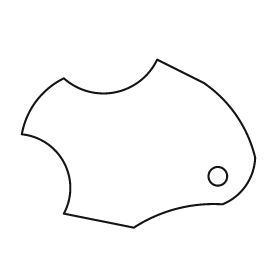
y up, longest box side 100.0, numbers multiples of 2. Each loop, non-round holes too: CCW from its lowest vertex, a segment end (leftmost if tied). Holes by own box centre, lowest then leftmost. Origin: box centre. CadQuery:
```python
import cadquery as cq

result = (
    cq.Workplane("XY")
    .moveTo(-2.0, -36.0)
    .threePointArc((16.0, -28.0), (36.0, -26.0))
    .threePointArc((46.0, -18.0), (50.0, -6.0))
    .threePointArc((42.0, 12.0), (28.0, 26.0))
    .lineTo(8.0, 36.0)
    .threePointArc((-10.0, 22.0), (-32.0, 28.0))
    .threePointArc((-44.0, 18.0), (-50.0, 4.0))
    .threePointArc((-32.0, -8.0), (-32.0, -30.0))
    .close()
    .moveTo(34.0, -14.0)
    .circle(4.0)
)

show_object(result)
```